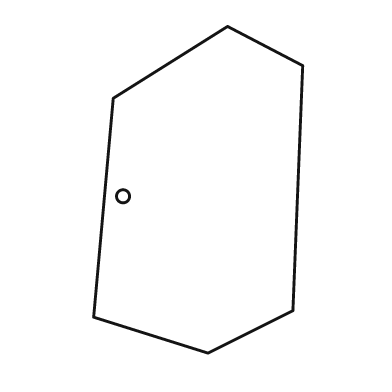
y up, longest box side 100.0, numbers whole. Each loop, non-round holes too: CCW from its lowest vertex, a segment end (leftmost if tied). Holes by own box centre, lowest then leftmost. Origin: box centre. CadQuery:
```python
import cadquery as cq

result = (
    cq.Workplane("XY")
    .moveTo(3.0, -50.0)
    .lineTo(29.0, -37.0)
    .lineTo(32.0, 38.0)
    .lineTo(9.0, 50.0)
    .lineTo(-26.0, 28.0)
    .lineTo(-32.0, -39.0)
    .close()
    .moveTo(-23.0, -2.0)
    .circle(2.0)
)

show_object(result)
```